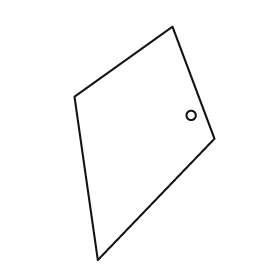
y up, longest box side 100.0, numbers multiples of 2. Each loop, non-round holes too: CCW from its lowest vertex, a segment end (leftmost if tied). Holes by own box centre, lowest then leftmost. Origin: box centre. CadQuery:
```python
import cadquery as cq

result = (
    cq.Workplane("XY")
    .moveTo(-20.0, -50.0)
    .lineTo(30.0, 2.0)
    .lineTo(12.0, 50.0)
    .lineTo(-30.0, 20.0)
    .close()
    .moveTo(20.0, 12.0)
    .circle(2.0)
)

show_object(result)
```